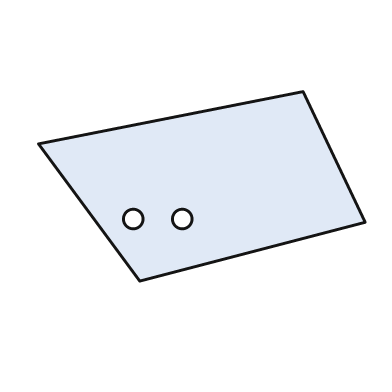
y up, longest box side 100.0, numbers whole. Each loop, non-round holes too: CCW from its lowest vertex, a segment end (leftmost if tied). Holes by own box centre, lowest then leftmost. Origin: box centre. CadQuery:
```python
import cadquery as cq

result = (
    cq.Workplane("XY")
    .moveTo(-19.0, -29.0)
    .lineTo(50.0, -11.0)
    .lineTo(31.0, 29.0)
    .lineTo(-50.0, 13.0)
    .close()
    .moveTo(-21.0, -10.0)
    .circle(3.0)
    .moveTo(-6.0, -10.0)
    .circle(3.0)
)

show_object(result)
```